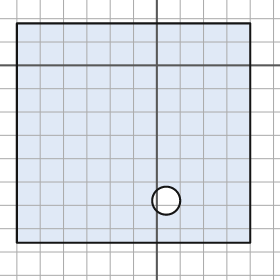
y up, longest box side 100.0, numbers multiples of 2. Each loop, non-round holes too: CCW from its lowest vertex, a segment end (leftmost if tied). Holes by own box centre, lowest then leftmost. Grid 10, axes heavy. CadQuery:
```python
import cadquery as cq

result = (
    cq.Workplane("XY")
    .moveTo(-60.0, -76.0)
    .lineTo(40.0, -76.0)
    .lineTo(40.0, 18.0)
    .lineTo(-60.0, 18.0)
    .close()
    .moveTo(4.0, -58.0)
    .circle(6.0)
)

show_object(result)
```